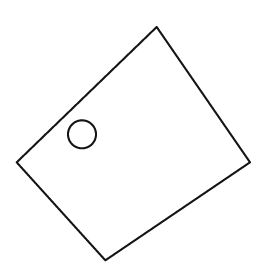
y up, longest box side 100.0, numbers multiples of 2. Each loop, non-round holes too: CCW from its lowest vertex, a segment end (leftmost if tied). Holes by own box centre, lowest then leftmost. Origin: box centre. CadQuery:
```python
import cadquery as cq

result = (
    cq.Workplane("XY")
    .moveTo(-12.0, -50.0)
    .lineTo(50.0, -8.0)
    .lineTo(10.0, 50.0)
    .lineTo(-50.0, -8.0)
    .close()
    .moveTo(-22.0, 4.0)
    .circle(6.0)
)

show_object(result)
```